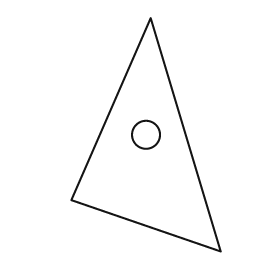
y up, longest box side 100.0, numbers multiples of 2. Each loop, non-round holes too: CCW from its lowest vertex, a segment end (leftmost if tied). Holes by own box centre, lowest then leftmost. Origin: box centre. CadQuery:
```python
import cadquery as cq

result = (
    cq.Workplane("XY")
    .moveTo(32.0, -50.0)
    .lineTo(2.0, 50.0)
    .lineTo(-32.0, -28.0)
    .close()
    .moveTo(0.0, 0.0)
    .circle(6.0)
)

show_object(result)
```